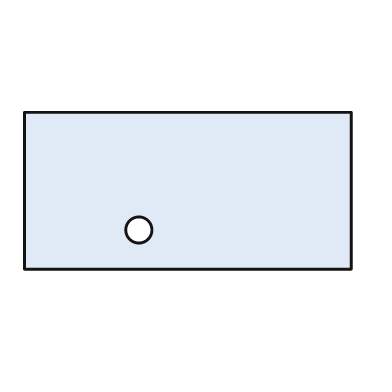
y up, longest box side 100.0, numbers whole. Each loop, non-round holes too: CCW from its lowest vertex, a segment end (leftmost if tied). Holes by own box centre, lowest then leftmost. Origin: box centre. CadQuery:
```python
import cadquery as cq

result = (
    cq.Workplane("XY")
    .moveTo(-50.0, -24.0)
    .lineTo(50.0, -24.0)
    .lineTo(50.0, 24.0)
    .lineTo(-50.0, 24.0)
    .close()
    .moveTo(-15.0, -12.0)
    .circle(4.0)
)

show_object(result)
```